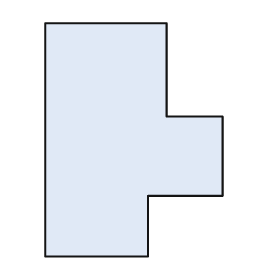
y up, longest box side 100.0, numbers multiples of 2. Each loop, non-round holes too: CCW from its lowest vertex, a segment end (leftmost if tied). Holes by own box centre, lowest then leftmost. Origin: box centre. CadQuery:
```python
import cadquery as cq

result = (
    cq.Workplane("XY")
    .moveTo(-38.0, -50.0)
    .lineTo(6.0, -50.0)
    .lineTo(6.0, -24.0)
    .lineTo(38.0, -24.0)
    .lineTo(38.0, 10.0)
    .lineTo(14.0, 10.0)
    .lineTo(14.0, 50.0)
    .lineTo(-38.0, 50.0)
    .close()
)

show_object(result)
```